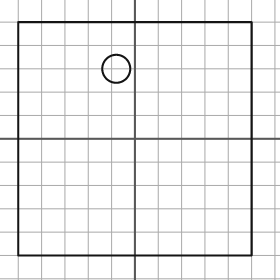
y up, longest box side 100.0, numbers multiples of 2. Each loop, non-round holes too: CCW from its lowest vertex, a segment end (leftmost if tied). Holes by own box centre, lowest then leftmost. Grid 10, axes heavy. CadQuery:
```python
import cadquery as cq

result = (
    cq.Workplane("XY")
    .moveTo(-50.0, -50.0)
    .lineTo(50.0, -50.0)
    .lineTo(50.0, 50.0)
    .lineTo(-50.0, 50.0)
    .close()
    .moveTo(-8.0, 30.0)
    .circle(6.0)
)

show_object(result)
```